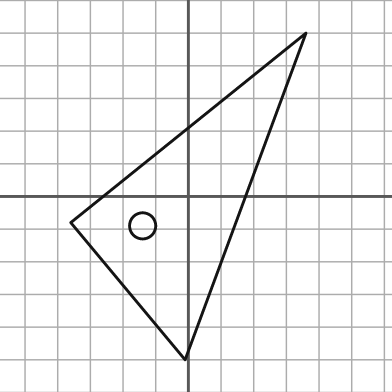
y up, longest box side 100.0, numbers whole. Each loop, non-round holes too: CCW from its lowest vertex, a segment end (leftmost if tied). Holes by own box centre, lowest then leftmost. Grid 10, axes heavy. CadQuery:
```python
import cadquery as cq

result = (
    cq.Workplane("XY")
    .moveTo(-1.0, -50.0)
    .lineTo(36.0, 50.0)
    .lineTo(-36.0, -8.0)
    .close()
    .moveTo(-14.0, -9.0)
    .circle(4.0)
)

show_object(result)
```